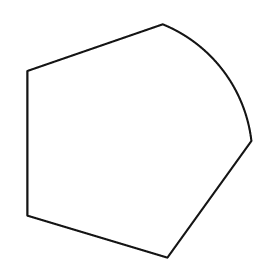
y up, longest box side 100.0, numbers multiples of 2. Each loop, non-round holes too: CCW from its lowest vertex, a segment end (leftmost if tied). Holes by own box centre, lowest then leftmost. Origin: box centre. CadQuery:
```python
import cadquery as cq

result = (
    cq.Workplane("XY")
    .moveTo(12.0, -50.0)
    .lineTo(48.0, 0.0)
    .threePointArc((36.0, 30.0), (10.0, 50.0))
    .lineTo(-48.0, 30.0)
    .lineTo(-48.0, -32.0)
    .close()
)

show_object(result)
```